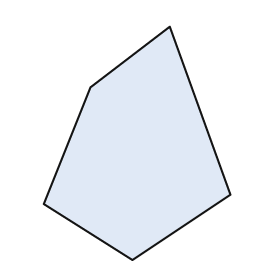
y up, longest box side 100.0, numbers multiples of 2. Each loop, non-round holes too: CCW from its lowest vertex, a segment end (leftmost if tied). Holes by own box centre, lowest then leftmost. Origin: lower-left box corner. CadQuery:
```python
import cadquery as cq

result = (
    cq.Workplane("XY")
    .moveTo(38.0, 0.0)
    .lineTo(80.0, 28.0)
    .lineTo(54.0, 100.0)
    .lineTo(20.0, 74.0)
    .lineTo(0.0, 24.0)
    .close()
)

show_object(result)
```